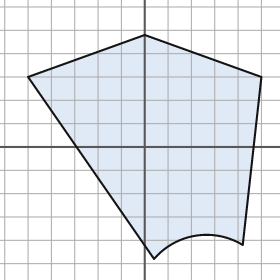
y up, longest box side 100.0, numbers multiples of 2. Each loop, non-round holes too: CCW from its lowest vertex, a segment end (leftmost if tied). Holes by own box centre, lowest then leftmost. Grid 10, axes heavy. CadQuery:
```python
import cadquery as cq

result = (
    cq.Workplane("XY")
    .moveTo(4.0, -48.0)
    .threePointArc((22.0, -38.0), (42.0, -42.0))
    .lineTo(50.0, 30.0)
    .lineTo(0.0, 48.0)
    .lineTo(-50.0, 30.0)
    .close()
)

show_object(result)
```